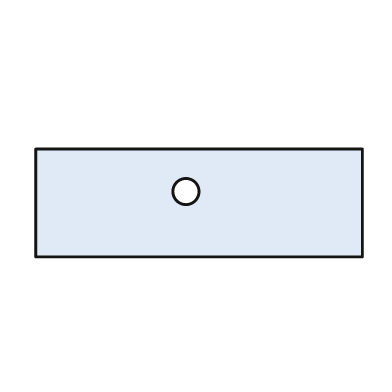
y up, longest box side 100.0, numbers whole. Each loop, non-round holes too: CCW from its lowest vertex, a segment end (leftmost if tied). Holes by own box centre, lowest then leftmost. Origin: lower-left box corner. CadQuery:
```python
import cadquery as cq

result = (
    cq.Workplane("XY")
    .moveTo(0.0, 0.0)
    .lineTo(100.0, 0.0)
    .lineTo(100.0, 33.0)
    .lineTo(0.0, 33.0)
    .close()
    .moveTo(46.0, 20.0)
    .circle(4.0)
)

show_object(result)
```